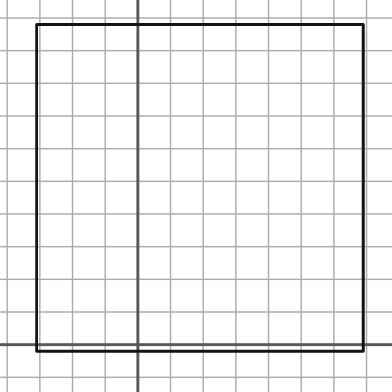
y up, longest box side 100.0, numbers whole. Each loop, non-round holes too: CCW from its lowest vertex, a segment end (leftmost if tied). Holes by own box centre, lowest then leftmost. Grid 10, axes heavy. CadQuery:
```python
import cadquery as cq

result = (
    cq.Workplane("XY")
    .moveTo(-31.0, -2.0)
    .lineTo(69.0, -2.0)
    .lineTo(69.0, 98.0)
    .lineTo(-31.0, 98.0)
    .close()
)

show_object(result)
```